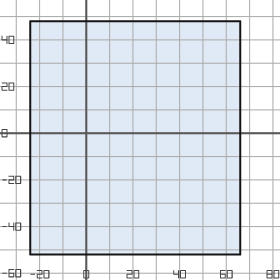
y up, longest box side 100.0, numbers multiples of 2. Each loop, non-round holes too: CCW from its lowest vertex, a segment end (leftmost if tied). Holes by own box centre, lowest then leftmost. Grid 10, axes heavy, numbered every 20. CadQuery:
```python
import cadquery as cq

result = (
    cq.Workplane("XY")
    .moveTo(-24.0, -52.0)
    .lineTo(66.0, -52.0)
    .lineTo(66.0, 48.0)
    .lineTo(-24.0, 48.0)
    .close()
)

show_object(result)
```